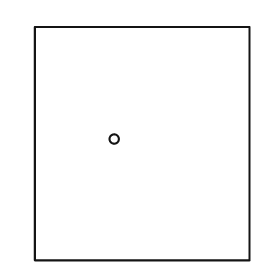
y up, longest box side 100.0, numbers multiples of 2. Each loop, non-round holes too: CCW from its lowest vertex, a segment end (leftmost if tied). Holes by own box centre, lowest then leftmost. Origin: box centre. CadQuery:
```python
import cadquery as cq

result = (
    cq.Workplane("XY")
    .moveTo(-46.0, -50.0)
    .lineTo(46.0, -50.0)
    .lineTo(46.0, 50.0)
    .lineTo(-46.0, 50.0)
    .close()
    .moveTo(-12.0, 2.0)
    .circle(2.0)
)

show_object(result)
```